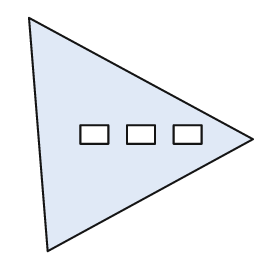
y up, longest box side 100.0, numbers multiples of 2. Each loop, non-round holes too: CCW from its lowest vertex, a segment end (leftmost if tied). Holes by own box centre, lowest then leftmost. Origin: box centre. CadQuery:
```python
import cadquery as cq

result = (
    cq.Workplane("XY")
    .moveTo(-40.0, -50.0)
    .lineTo(48.0, -2.0)
    .lineTo(-48.0, 50.0)
    .close()
    .moveTo(-26.0, -4.0)
    .lineTo(-14.0, -4.0)
    .lineTo(-14.0, 4.0)
    .lineTo(-26.0, 4.0)
    .close()
    .moveTo(-6.0, -4.0)
    .lineTo(6.0, -4.0)
    .lineTo(6.0, 4.0)
    .lineTo(-6.0, 4.0)
    .close()
    .moveTo(14.0, -4.0)
    .lineTo(26.0, -4.0)
    .lineTo(26.0, 4.0)
    .lineTo(14.0, 4.0)
    .close()
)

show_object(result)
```